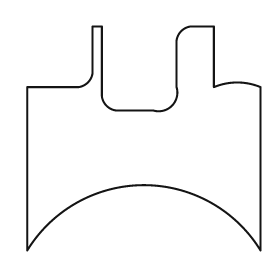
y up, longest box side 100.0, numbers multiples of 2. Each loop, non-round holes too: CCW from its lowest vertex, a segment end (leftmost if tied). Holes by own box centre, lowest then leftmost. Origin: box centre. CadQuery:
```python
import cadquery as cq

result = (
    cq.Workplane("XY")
    .moveTo(-50.0, -48.0)
    .threePointArc((0.0, -20.0), (50.0, -48.0))
    .lineTo(50.0, 22.0)
    .threePointArc((40.0, 24.0), (30.0, 22.0))
    .lineTo(30.0, 48.0)
    .lineTo(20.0, 48.0)
    .threePointArc((16.0, 46.0), (14.0, 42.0))
    .lineTo(14.0, 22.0)
    .threePointArc((12.0, 14.0), (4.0, 12.0))
    .lineTo(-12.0, 12.0)
    .threePointArc((-16.0, 14.0), (-18.0, 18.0))
    .lineTo(-18.0, 48.0)
    .lineTo(-22.0, 48.0)
    .lineTo(-22.0, 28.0)
    .threePointArc((-24.0, 24.0), (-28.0, 22.0))
    .lineTo(-50.0, 22.0)
    .close()
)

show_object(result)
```